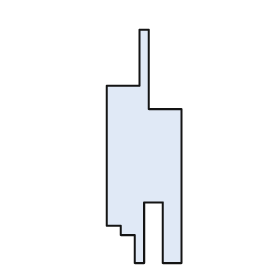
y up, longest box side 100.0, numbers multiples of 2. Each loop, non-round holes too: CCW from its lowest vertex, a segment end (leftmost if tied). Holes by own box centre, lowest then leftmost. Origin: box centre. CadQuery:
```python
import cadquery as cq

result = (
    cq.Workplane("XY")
    .moveTo(-4.0, -50.0)
    .lineTo(0.0, -50.0)
    .lineTo(0.0, -24.0)
    .lineTo(8.0, -24.0)
    .lineTo(8.0, -50.0)
    .lineTo(16.0, -50.0)
    .lineTo(16.0, 16.0)
    .lineTo(2.0, 16.0)
    .lineTo(2.0, 50.0)
    .lineTo(-2.0, 50.0)
    .lineTo(-2.0, 26.0)
    .lineTo(-16.0, 26.0)
    .lineTo(-16.0, -34.0)
    .lineTo(-10.0, -34.0)
    .lineTo(-10.0, -38.0)
    .lineTo(-4.0, -38.0)
    .close()
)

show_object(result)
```